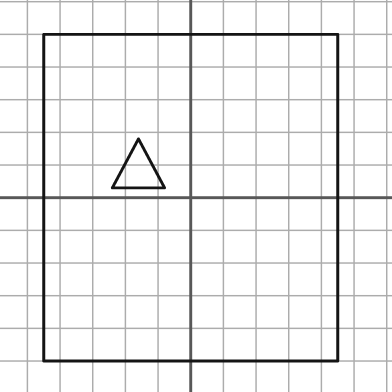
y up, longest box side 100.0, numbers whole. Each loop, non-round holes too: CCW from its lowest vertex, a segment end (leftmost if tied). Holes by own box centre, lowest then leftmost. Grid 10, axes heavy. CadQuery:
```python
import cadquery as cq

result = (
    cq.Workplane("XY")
    .moveTo(-45.0, -50.0)
    .lineTo(45.0, -50.0)
    .lineTo(45.0, 50.0)
    .lineTo(-45.0, 50.0)
    .close()
    .moveTo(-24.0, 3.0)
    .lineTo(-8.0, 3.0)
    .lineTo(-16.0, 18.0)
    .close()
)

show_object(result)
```